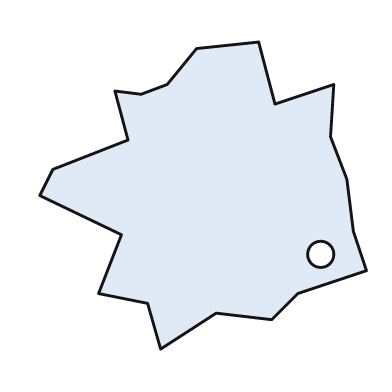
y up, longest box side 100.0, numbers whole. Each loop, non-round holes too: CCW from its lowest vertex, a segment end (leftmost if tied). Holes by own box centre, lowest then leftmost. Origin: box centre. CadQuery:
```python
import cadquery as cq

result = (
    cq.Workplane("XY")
    .moveTo(-13.0, -47.0)
    .lineTo(4.0, -36.0)
    .lineTo(21.0, -38.0)
    .lineTo(29.0, -30.0)
    .lineTo(50.0, -23.0)
    .lineTo(46.0, -11.0)
    .lineTo(44.0, 5.0)
    .lineTo(39.0, 18.0)
    .lineTo(40.0, 34.0)
    .lineTo(22.0, 28.0)
    .lineTo(17.0, 47.0)
    .lineTo(-2.0, 45.0)
    .lineTo(-11.0, 34.0)
    .lineTo(-19.0, 31.0)
    .lineTo(-27.0, 32.0)
    .lineTo(-23.0, 17.0)
    .lineTo(-46.0, 8.0)
    .lineTo(-50.0, 0.0)
    .lineTo(-25.0, -12.0)
    .lineTo(-32.0, -30.0)
    .lineTo(-17.0, -33.0)
    .close()
    .moveTo(36.0, -18.0)
    .circle(4.0)
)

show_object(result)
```